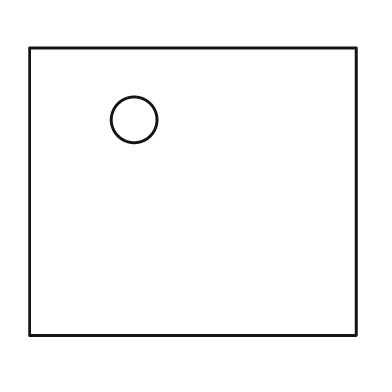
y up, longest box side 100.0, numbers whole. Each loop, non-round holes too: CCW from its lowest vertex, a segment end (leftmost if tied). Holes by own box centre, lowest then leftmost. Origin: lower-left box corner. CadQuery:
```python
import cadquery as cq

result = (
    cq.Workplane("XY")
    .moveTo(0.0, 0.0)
    .lineTo(100.0, 0.0)
    .lineTo(100.0, 88.0)
    .lineTo(0.0, 88.0)
    .close()
    .moveTo(32.0, 66.0)
    .circle(7.0)
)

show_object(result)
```